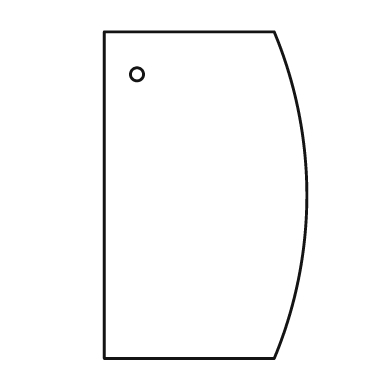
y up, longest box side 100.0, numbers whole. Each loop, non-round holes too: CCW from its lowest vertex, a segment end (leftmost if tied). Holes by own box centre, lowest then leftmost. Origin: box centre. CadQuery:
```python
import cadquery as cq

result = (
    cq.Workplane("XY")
    .moveTo(-31.0, -50.0)
    .lineTo(21.0, -50.0)
    .threePointArc((31.0, 0.0), (21.0, 50.0))
    .lineTo(-31.0, 50.0)
    .close()
    .moveTo(-21.0, 37.0)
    .circle(2.0)
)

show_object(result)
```